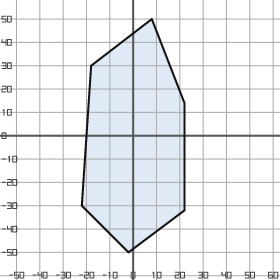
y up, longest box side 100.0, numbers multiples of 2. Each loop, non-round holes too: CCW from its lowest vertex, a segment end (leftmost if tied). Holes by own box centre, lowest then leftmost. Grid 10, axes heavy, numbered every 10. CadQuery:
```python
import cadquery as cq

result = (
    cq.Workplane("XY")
    .moveTo(-2.0, -50.0)
    .lineTo(22.0, -32.0)
    .lineTo(22.0, 14.0)
    .lineTo(8.0, 50.0)
    .lineTo(-18.0, 30.0)
    .lineTo(-22.0, -30.0)
    .close()
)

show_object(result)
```